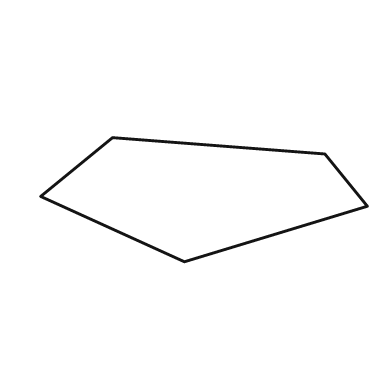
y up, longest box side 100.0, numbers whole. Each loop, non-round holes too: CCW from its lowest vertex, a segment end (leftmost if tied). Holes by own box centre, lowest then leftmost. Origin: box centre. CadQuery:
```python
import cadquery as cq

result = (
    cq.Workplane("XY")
    .moveTo(-6.0, -19.0)
    .lineTo(50.0, -2.0)
    .lineTo(37.0, 14.0)
    .lineTo(-28.0, 19.0)
    .lineTo(-50.0, 1.0)
    .close()
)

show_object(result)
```